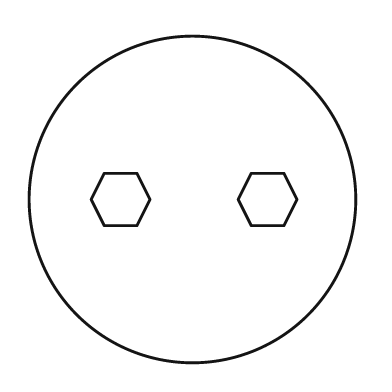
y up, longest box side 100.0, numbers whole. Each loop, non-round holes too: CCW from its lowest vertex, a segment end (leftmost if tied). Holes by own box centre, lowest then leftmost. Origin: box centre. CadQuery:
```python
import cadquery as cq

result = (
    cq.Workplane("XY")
    .moveTo(0.0, 0.0)
    .circle(50.0)
    .moveTo(-27.0, -8.0)
    .lineTo(-17.0, -8.0)
    .lineTo(-13.0, 0.0)
    .lineTo(-17.0, 8.0)
    .lineTo(-27.0, 8.0)
    .lineTo(-31.0, 0.0)
    .close()
    .moveTo(18.0, -8.0)
    .lineTo(28.0, -8.0)
    .lineTo(32.0, 0.0)
    .lineTo(28.0, 8.0)
    .lineTo(18.0, 8.0)
    .lineTo(14.0, 0.0)
    .close()
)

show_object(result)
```